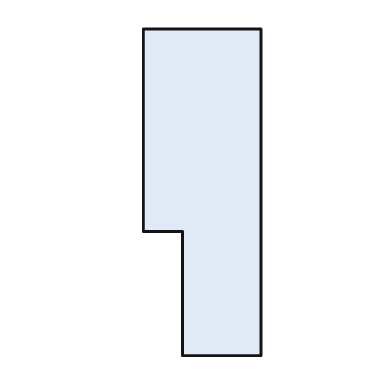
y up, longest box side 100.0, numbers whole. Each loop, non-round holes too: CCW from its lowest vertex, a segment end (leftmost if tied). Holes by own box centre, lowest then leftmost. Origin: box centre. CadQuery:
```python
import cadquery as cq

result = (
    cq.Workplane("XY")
    .moveTo(-6.0, -50.0)
    .lineTo(18.0, -50.0)
    .lineTo(18.0, 50.0)
    .lineTo(-18.0, 50.0)
    .lineTo(-18.0, -12.0)
    .lineTo(-6.0, -12.0)
    .close()
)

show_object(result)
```